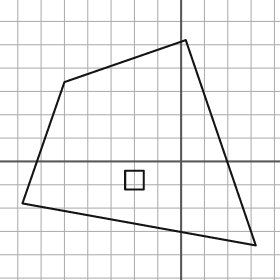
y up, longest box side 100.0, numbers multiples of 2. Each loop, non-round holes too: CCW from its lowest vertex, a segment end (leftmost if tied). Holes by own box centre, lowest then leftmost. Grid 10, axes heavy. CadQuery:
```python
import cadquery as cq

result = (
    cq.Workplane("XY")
    .moveTo(32.0, -36.0)
    .lineTo(2.0, 52.0)
    .lineTo(-50.0, 34.0)
    .lineTo(-68.0, -18.0)
    .close()
    .moveTo(-24.0, -12.0)
    .lineTo(-16.0, -12.0)
    .lineTo(-16.0, -4.0)
    .lineTo(-24.0, -4.0)
    .close()
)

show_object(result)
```